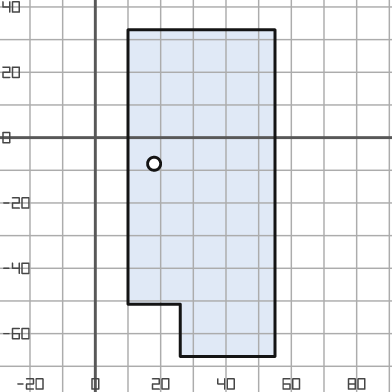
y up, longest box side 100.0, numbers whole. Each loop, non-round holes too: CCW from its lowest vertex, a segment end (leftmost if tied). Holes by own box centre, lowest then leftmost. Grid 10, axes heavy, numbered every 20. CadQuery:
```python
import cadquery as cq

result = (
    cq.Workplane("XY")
    .moveTo(26.0, -67.0)
    .lineTo(55.0, -67.0)
    .lineTo(55.0, 33.0)
    .lineTo(10.0, 33.0)
    .lineTo(10.0, -51.0)
    .lineTo(26.0, -51.0)
    .close()
    .moveTo(18.0, -8.0)
    .circle(2.0)
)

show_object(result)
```